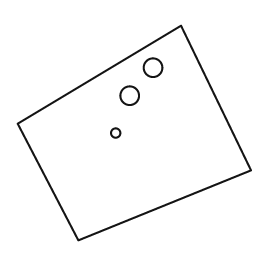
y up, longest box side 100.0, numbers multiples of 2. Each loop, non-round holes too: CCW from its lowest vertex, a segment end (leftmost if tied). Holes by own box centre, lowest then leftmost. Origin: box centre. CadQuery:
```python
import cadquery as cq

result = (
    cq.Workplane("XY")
    .moveTo(-24.0, -46.0)
    .lineTo(50.0, -16.0)
    .lineTo(20.0, 46.0)
    .lineTo(-50.0, 4.0)
    .close()
    .moveTo(-8.0, 0.0)
    .circle(2.0)
    .moveTo(-2.0, 16.0)
    .circle(4.0)
    .moveTo(8.0, 28.0)
    .circle(4.0)
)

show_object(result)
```